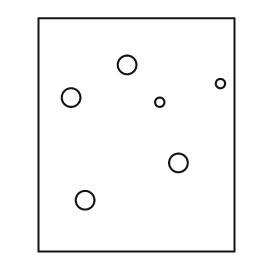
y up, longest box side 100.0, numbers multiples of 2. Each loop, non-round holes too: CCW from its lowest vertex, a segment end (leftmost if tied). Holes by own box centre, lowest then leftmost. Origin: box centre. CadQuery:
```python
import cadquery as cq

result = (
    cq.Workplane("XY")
    .moveTo(-42.0, -50.0)
    .lineTo(42.0, -50.0)
    .lineTo(42.0, 50.0)
    .lineTo(-42.0, 50.0)
    .close()
    .moveTo(-22.0, -28.0)
    .circle(4.0)
    .moveTo(18.0, -12.0)
    .circle(4.0)
    .moveTo(10.0, 14.0)
    .circle(2.0)
    .moveTo(-28.0, 16.0)
    .circle(4.0)
    .moveTo(36.0, 22.0)
    .circle(2.0)
    .moveTo(-4.0, 30.0)
    .circle(4.0)
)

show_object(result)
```